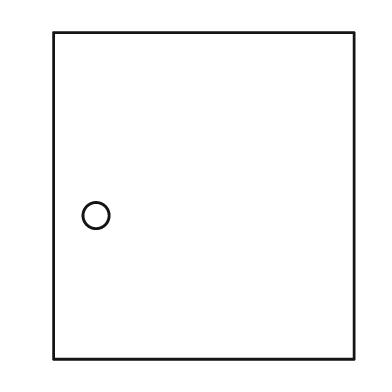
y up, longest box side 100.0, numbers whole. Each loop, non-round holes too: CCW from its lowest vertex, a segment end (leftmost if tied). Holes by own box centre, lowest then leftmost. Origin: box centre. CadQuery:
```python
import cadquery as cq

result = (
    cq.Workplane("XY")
    .moveTo(-46.0, -50.0)
    .lineTo(46.0, -50.0)
    .lineTo(46.0, 50.0)
    .lineTo(-46.0, 50.0)
    .close()
    .moveTo(-33.0, -6.0)
    .circle(4.0)
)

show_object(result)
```